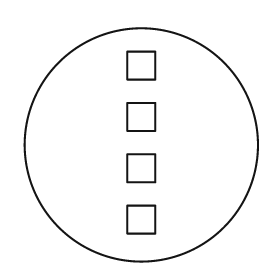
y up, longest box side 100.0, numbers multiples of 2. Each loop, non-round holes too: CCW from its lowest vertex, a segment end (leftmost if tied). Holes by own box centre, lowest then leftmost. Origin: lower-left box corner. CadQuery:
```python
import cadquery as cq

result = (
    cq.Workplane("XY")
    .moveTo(50.0, 50.0)
    .circle(50.0)
    .moveTo(44.0, 12.0)
    .lineTo(56.0, 12.0)
    .lineTo(56.0, 24.0)
    .lineTo(44.0, 24.0)
    .close()
    .moveTo(44.0, 34.0)
    .lineTo(56.0, 34.0)
    .lineTo(56.0, 46.0)
    .lineTo(44.0, 46.0)
    .close()
    .moveTo(44.0, 56.0)
    .lineTo(56.0, 56.0)
    .lineTo(56.0, 68.0)
    .lineTo(44.0, 68.0)
    .close()
    .moveTo(44.0, 78.0)
    .lineTo(56.0, 78.0)
    .lineTo(56.0, 90.0)
    .lineTo(44.0, 90.0)
    .close()
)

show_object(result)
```